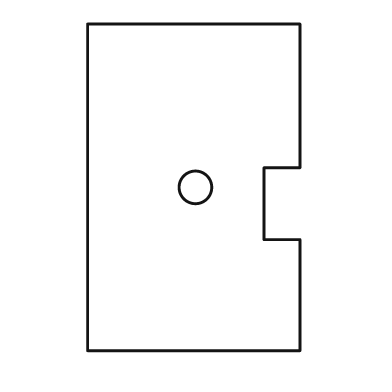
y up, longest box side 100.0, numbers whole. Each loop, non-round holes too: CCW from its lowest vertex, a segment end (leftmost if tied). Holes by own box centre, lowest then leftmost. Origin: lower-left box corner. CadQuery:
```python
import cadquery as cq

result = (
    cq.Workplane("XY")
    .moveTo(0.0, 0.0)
    .lineTo(65.0, 0.0)
    .lineTo(65.0, 34.0)
    .lineTo(54.0, 34.0)
    .lineTo(54.0, 56.0)
    .lineTo(65.0, 56.0)
    .lineTo(65.0, 100.0)
    .lineTo(0.0, 100.0)
    .close()
    .moveTo(33.0, 50.0)
    .circle(5.0)
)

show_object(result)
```